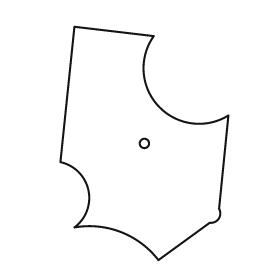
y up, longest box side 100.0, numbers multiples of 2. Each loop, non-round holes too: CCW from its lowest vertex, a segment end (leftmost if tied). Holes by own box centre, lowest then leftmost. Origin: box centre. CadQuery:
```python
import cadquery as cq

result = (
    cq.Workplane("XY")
    .moveTo(6.0, -50.0)
    .lineTo(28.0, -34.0)
    .threePointArc((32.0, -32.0), (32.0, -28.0))
    .lineTo(36.0, 12.0)
    .threePointArc((6.0, 16.0), (4.0, 46.0))
    .lineTo(-30.0, 50.0)
    .lineTo(-36.0, -8.0)
    .threePointArc((-24.0, -20.0), (-30.0, -36.0))
    .threePointArc((-10.0, -38.0), (6.0, -50.0))
    .close()
    .moveTo(0.0, 0.0)
    .circle(2.0)
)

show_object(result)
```